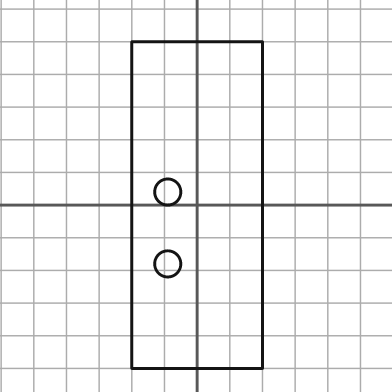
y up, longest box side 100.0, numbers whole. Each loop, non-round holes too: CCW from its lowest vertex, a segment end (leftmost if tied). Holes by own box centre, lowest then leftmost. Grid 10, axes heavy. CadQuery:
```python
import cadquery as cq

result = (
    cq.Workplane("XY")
    .moveTo(-20.0, -50.0)
    .lineTo(20.0, -50.0)
    .lineTo(20.0, 50.0)
    .lineTo(-20.0, 50.0)
    .close()
    .moveTo(-9.0, -18.0)
    .circle(4.0)
    .moveTo(-9.0, 4.0)
    .circle(4.0)
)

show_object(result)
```